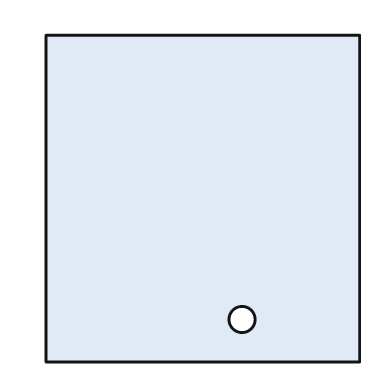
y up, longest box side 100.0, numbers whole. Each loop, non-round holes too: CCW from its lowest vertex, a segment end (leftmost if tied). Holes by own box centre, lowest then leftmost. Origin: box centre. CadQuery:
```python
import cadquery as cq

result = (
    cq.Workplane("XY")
    .moveTo(-48.0, -50.0)
    .lineTo(48.0, -50.0)
    .lineTo(48.0, 50.0)
    .lineTo(-48.0, 50.0)
    .close()
    .moveTo(12.0, -37.0)
    .circle(4.0)
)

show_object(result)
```